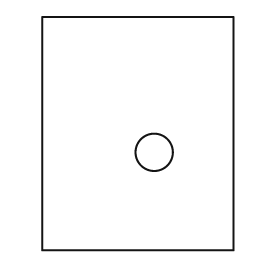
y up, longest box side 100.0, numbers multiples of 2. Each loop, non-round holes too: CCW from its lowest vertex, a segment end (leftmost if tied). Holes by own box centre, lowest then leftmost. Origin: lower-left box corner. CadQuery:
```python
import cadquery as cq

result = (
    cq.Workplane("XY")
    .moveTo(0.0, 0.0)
    .lineTo(82.0, 0.0)
    .lineTo(82.0, 100.0)
    .lineTo(0.0, 100.0)
    .close()
    .moveTo(48.0, 42.0)
    .circle(8.0)
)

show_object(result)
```